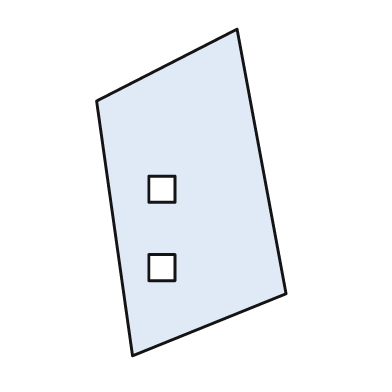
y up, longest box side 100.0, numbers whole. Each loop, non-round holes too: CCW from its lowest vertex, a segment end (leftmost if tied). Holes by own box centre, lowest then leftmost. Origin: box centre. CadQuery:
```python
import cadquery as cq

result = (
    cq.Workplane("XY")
    .moveTo(-18.0, -50.0)
    .lineTo(29.0, -31.0)
    .lineTo(14.0, 50.0)
    .lineTo(-29.0, 28.0)
    .close()
    .moveTo(-13.0, -27.0)
    .lineTo(-5.0, -27.0)
    .lineTo(-5.0, -19.0)
    .lineTo(-13.0, -19.0)
    .close()
    .moveTo(-13.0, -3.0)
    .lineTo(-5.0, -3.0)
    .lineTo(-5.0, 5.0)
    .lineTo(-13.0, 5.0)
    .close()
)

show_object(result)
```